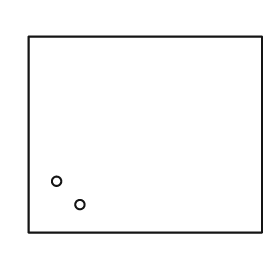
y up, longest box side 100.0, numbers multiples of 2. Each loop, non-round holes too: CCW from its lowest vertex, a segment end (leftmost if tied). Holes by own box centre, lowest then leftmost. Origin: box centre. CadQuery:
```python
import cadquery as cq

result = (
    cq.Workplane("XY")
    .moveTo(-50.0, -42.0)
    .lineTo(50.0, -42.0)
    .lineTo(50.0, 42.0)
    .lineTo(-50.0, 42.0)
    .close()
    .moveTo(-28.0, -30.0)
    .circle(2.0)
    .moveTo(-38.0, -20.0)
    .circle(2.0)
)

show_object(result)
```